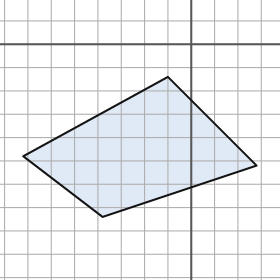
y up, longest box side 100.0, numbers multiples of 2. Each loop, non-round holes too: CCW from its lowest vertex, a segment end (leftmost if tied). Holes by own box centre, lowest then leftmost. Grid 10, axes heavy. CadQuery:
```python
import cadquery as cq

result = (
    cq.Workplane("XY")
    .moveTo(-38.0, -74.0)
    .lineTo(28.0, -52.0)
    .lineTo(-10.0, -14.0)
    .lineTo(-72.0, -48.0)
    .close()
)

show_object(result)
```